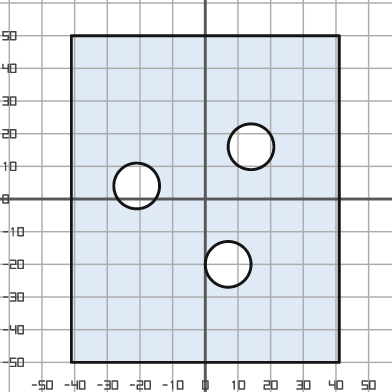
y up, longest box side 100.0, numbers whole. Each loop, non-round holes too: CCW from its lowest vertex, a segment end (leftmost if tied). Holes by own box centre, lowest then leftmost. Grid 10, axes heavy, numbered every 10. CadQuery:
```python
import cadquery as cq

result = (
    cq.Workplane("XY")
    .moveTo(-41.0, -50.0)
    .lineTo(41.0, -50.0)
    .lineTo(41.0, 50.0)
    .lineTo(-41.0, 50.0)
    .close()
    .moveTo(7.0, -20.0)
    .circle(7.0)
    .moveTo(-21.0, 4.0)
    .circle(7.0)
    .moveTo(14.0, 16.0)
    .circle(7.0)
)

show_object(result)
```